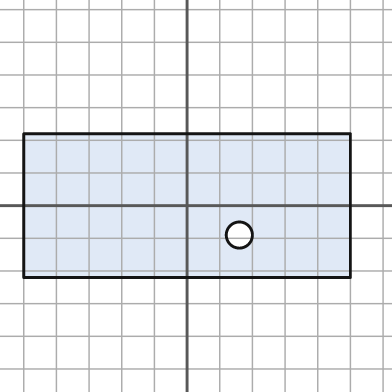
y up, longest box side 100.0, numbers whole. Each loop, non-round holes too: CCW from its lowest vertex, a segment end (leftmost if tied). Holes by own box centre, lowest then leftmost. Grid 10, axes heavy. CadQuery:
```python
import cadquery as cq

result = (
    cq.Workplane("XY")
    .moveTo(-50.0, -22.0)
    .lineTo(50.0, -22.0)
    .lineTo(50.0, 22.0)
    .lineTo(-50.0, 22.0)
    .close()
    .moveTo(16.0, -9.0)
    .circle(4.0)
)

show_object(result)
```